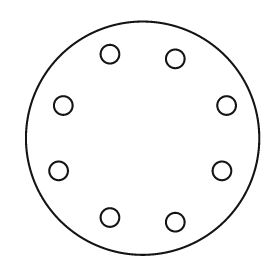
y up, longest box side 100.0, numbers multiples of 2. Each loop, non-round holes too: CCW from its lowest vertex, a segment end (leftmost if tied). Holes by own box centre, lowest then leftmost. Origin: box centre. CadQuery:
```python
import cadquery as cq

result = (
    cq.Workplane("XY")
    .moveTo(0.0, 0.0)
    .circle(50.0)
    .moveTo(14.0, -36.0)
    .circle(4.0)
    .moveTo(-14.0, -34.0)
    .circle(4.0)
    .moveTo(-36.0, -14.0)
    .circle(4.0)
    .moveTo(34.0, -14.0)
    .circle(4.0)
    .moveTo(-34.0, 14.0)
    .circle(4.0)
    .moveTo(36.0, 14.0)
    .circle(4.0)
    .moveTo(14.0, 34.0)
    .circle(4.0)
    .moveTo(-14.0, 36.0)
    .circle(4.0)
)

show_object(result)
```